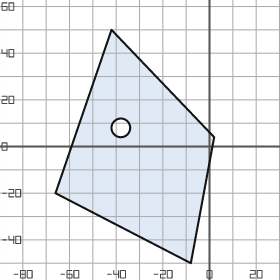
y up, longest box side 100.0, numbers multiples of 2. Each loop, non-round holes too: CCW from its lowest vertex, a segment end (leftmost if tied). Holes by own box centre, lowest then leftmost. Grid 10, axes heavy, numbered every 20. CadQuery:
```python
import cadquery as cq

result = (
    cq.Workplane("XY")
    .moveTo(-8.0, -50.0)
    .lineTo(2.0, 4.0)
    .lineTo(-42.0, 50.0)
    .lineTo(-66.0, -20.0)
    .close()
    .moveTo(-38.0, 8.0)
    .circle(4.0)
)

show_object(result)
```